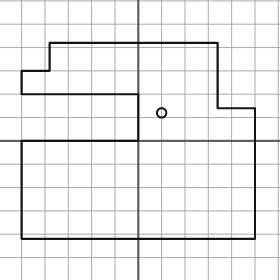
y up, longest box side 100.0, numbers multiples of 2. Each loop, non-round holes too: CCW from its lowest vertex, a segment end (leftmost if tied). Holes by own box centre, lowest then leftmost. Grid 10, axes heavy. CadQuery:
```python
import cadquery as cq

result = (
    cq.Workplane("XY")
    .moveTo(-50.0, -42.0)
    .lineTo(50.0, -42.0)
    .lineTo(50.0, 14.0)
    .lineTo(34.0, 14.0)
    .lineTo(34.0, 42.0)
    .lineTo(-38.0, 42.0)
    .lineTo(-38.0, 30.0)
    .lineTo(-50.0, 30.0)
    .lineTo(-50.0, 20.0)
    .lineTo(0.0, 20.0)
    .lineTo(0.0, 0.0)
    .lineTo(-50.0, 0.0)
    .close()
    .moveTo(10.0, 12.0)
    .circle(2.0)
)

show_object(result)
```